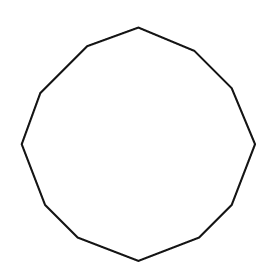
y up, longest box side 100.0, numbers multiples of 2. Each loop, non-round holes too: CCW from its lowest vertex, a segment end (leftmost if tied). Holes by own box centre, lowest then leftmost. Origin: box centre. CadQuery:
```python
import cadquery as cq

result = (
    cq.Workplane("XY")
    .moveTo(0.0, -50.0)
    .lineTo(26.0, -40.0)
    .lineTo(40.0, -26.0)
    .lineTo(50.0, 0.0)
    .lineTo(40.0, 24.0)
    .lineTo(24.0, 40.0)
    .lineTo(0.0, 50.0)
    .lineTo(-22.0, 42.0)
    .lineTo(-42.0, 22.0)
    .lineTo(-50.0, 0.0)
    .lineTo(-40.0, -26.0)
    .lineTo(-26.0, -40.0)
    .close()
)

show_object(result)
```